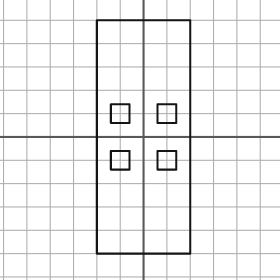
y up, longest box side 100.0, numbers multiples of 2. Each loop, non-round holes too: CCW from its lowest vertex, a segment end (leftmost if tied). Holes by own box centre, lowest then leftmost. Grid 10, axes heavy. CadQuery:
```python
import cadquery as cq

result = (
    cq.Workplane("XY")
    .moveTo(-20.0, -50.0)
    .lineTo(20.0, -50.0)
    .lineTo(20.0, 50.0)
    .lineTo(-20.0, 50.0)
    .close()
    .moveTo(-14.0, -14.0)
    .lineTo(-6.0, -14.0)
    .lineTo(-6.0, -6.0)
    .lineTo(-14.0, -6.0)
    .close()
    .moveTo(6.0, -14.0)
    .lineTo(14.0, -14.0)
    .lineTo(14.0, -6.0)
    .lineTo(6.0, -6.0)
    .close()
    .moveTo(-14.0, 6.0)
    .lineTo(-6.0, 6.0)
    .lineTo(-6.0, 14.0)
    .lineTo(-14.0, 14.0)
    .close()
    .moveTo(6.0, 6.0)
    .lineTo(14.0, 6.0)
    .lineTo(14.0, 14.0)
    .lineTo(6.0, 14.0)
    .close()
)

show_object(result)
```